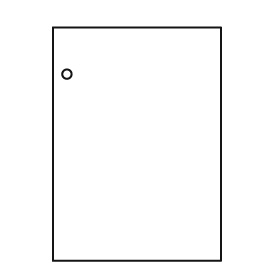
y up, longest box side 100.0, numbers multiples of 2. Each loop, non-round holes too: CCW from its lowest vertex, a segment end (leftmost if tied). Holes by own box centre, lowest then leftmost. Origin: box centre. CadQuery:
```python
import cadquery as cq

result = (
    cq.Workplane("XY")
    .moveTo(-36.0, -50.0)
    .lineTo(36.0, -50.0)
    .lineTo(36.0, 50.0)
    .lineTo(-36.0, 50.0)
    .close()
    .moveTo(-30.0, 30.0)
    .circle(2.0)
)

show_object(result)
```